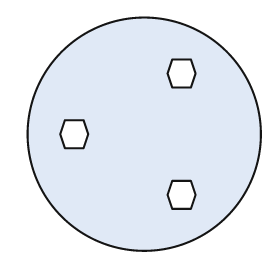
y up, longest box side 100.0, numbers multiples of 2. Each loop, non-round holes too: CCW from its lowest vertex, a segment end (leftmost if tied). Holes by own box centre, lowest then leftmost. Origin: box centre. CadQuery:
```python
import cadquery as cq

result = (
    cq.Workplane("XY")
    .moveTo(0.0, 0.0)
    .circle(50.0)
    .moveTo(12.0, -32.0)
    .lineTo(20.0, -32.0)
    .lineTo(22.0, -26.0)
    .lineTo(20.0, -20.0)
    .lineTo(12.0, -20.0)
    .lineTo(10.0, -26.0)
    .close()
    .moveTo(-34.0, -6.0)
    .lineTo(-26.0, -6.0)
    .lineTo(-24.0, 0.0)
    .lineTo(-26.0, 6.0)
    .lineTo(-34.0, 6.0)
    .lineTo(-36.0, 0.0)
    .close()
    .moveTo(12.0, 20.0)
    .lineTo(20.0, 20.0)
    .lineTo(22.0, 26.0)
    .lineTo(20.0, 32.0)
    .lineTo(12.0, 32.0)
    .lineTo(10.0, 26.0)
    .close()
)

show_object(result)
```